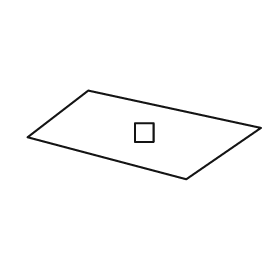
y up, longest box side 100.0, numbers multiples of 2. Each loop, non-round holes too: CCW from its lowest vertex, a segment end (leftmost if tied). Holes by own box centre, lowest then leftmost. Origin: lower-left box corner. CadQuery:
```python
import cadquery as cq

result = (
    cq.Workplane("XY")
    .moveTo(68.0, 0.0)
    .lineTo(100.0, 22.0)
    .lineTo(26.0, 38.0)
    .lineTo(0.0, 18.0)
    .close()
    .moveTo(46.0, 16.0)
    .lineTo(54.0, 16.0)
    .lineTo(54.0, 24.0)
    .lineTo(46.0, 24.0)
    .close()
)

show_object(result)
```